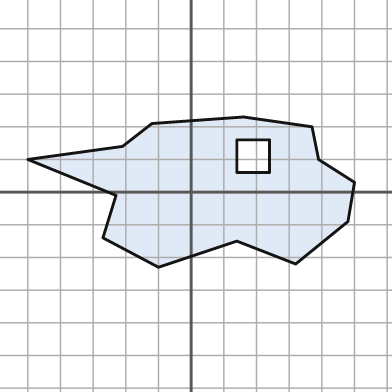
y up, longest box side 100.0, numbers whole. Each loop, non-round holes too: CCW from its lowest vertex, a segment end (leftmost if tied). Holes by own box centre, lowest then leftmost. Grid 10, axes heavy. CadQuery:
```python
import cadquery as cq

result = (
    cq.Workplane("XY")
    .moveTo(-10.0, -23.0)
    .lineTo(14.0, -15.0)
    .lineTo(32.0, -22.0)
    .lineTo(48.0, -9.0)
    .lineTo(50.0, 3.0)
    .lineTo(39.0, 10.0)
    .lineTo(37.0, 20.0)
    .lineTo(16.0, 23.0)
    .lineTo(-12.0, 21.0)
    .lineTo(-21.0, 14.0)
    .lineTo(-50.0, 10.0)
    .lineTo(-23.0, -1.0)
    .lineTo(-27.0, -14.0)
    .close()
    .moveTo(14.0, 6.0)
    .lineTo(24.0, 6.0)
    .lineTo(24.0, 16.0)
    .lineTo(14.0, 16.0)
    .close()
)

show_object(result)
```